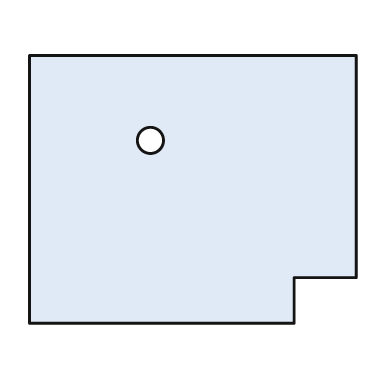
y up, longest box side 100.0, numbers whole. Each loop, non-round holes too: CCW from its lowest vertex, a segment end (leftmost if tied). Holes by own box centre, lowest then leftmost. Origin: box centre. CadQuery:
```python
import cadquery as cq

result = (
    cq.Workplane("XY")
    .moveTo(-50.0, -41.0)
    .lineTo(31.0, -41.0)
    .lineTo(31.0, -27.0)
    .lineTo(50.0, -27.0)
    .lineTo(50.0, 41.0)
    .lineTo(-50.0, 41.0)
    .close()
    .moveTo(-13.0, 15.0)
    .circle(4.0)
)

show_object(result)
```